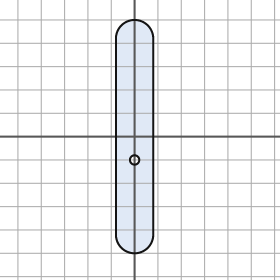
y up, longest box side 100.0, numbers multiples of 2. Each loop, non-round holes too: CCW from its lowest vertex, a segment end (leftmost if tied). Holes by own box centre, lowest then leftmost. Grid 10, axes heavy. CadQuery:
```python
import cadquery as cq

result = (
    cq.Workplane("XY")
    .moveTo(-8.0, -42.0)
    .threePointArc((0.0, -50.0), (8.0, -42.0))
    .lineTo(8.0, 42.0)
    .threePointArc((0.0, 50.0), (-8.0, 42.0))
    .close()
    .moveTo(0.0, -10.0)
    .circle(2.0)
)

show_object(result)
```